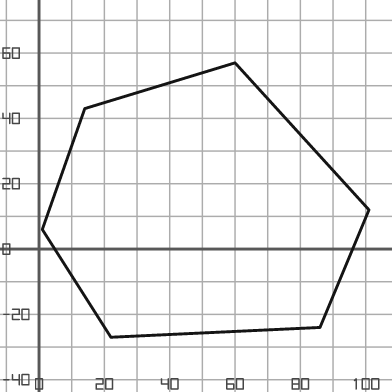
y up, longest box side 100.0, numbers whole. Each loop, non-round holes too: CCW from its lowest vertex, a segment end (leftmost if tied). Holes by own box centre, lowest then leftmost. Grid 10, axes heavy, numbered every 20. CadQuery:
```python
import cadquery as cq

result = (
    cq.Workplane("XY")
    .moveTo(22.0, -27.0)
    .lineTo(86.0, -24.0)
    .lineTo(101.0, 12.0)
    .lineTo(60.0, 57.0)
    .lineTo(14.0, 43.0)
    .lineTo(1.0, 6.0)
    .close()
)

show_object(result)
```